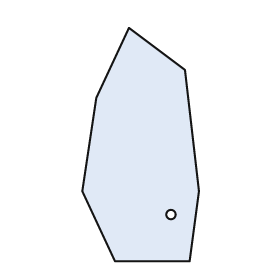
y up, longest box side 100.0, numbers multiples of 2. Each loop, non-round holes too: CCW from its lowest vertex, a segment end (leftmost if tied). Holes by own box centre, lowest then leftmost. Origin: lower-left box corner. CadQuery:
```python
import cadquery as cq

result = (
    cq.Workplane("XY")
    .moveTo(14.0, 0.0)
    .lineTo(46.0, 0.0)
    .lineTo(50.0, 30.0)
    .lineTo(44.0, 82.0)
    .lineTo(20.0, 100.0)
    .lineTo(6.0, 70.0)
    .lineTo(0.0, 30.0)
    .close()
    .moveTo(38.0, 20.0)
    .circle(2.0)
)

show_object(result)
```